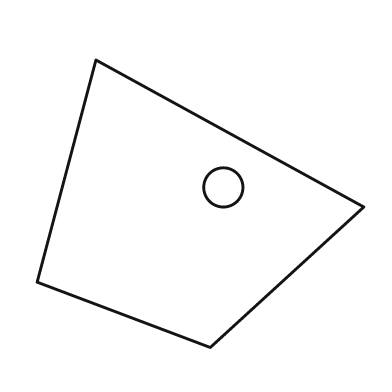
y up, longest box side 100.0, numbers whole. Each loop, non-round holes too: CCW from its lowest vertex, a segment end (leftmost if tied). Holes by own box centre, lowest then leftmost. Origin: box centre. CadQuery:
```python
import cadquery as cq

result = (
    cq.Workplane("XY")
    .moveTo(3.0, -44.0)
    .lineTo(50.0, -1.0)
    .lineTo(-32.0, 44.0)
    .lineTo(-50.0, -24.0)
    .close()
    .moveTo(7.0, 5.0)
    .circle(6.0)
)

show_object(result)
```